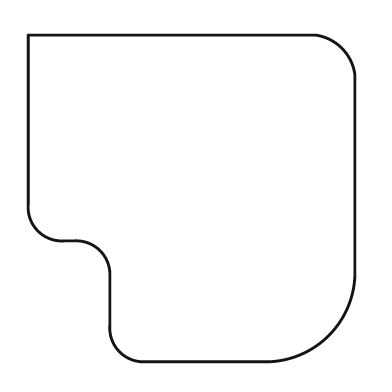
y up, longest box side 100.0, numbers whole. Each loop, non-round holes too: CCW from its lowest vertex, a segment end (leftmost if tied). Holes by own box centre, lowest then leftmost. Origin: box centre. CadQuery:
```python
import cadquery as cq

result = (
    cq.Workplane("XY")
    .moveTo(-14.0, -50.0)
    .lineTo(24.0, -50.0)
    .threePointArc((42.0, -42.0), (50.0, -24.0))
    .lineTo(50.0, 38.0)
    .threePointArc((46.0, 46.0), (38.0, 50.0))
    .lineTo(-50.0, 50.0)
    .lineTo(-50.0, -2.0)
    .threePointArc((-47.0, -10.0), (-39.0, -13.0))
    .lineTo(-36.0, -13.0)
    .threePointArc((-28.0, -16.0), (-25.0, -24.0))
    .lineTo(-25.0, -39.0)
    .threePointArc((-22.0, -47.0), (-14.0, -50.0))
    .close()
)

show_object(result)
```